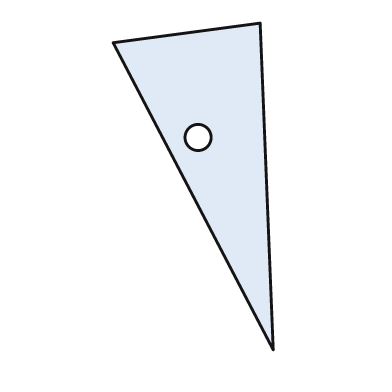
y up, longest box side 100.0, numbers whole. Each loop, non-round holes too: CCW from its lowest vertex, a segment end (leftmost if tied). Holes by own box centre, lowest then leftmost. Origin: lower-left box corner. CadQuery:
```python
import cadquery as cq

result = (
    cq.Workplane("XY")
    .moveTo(49.0, 0.0)
    .lineTo(45.0, 100.0)
    .lineTo(0.0, 94.0)
    .close()
    .moveTo(26.0, 65.0)
    .circle(4.0)
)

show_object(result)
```